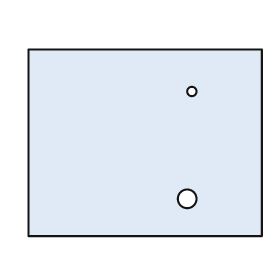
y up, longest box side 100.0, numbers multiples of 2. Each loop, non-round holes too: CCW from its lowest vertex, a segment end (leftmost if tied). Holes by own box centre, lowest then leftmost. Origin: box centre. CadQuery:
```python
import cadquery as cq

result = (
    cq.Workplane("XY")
    .moveTo(-50.0, -40.0)
    .lineTo(50.0, -40.0)
    .lineTo(50.0, 40.0)
    .lineTo(-50.0, 40.0)
    .close()
    .moveTo(18.0, -24.0)
    .circle(4.0)
    .moveTo(20.0, 22.0)
    .circle(2.0)
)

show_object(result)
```